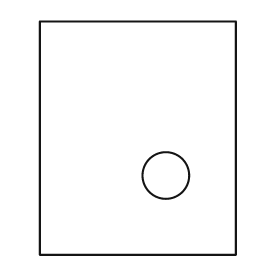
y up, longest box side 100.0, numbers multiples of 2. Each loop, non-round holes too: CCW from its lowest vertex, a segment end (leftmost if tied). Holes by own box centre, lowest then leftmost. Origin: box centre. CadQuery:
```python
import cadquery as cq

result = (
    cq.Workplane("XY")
    .moveTo(-42.0, -50.0)
    .lineTo(42.0, -50.0)
    .lineTo(42.0, 50.0)
    .lineTo(-42.0, 50.0)
    .close()
    .moveTo(12.0, -16.0)
    .circle(10.0)
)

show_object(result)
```